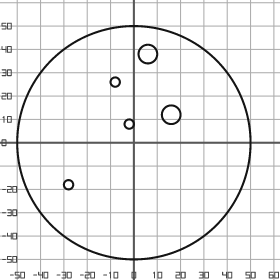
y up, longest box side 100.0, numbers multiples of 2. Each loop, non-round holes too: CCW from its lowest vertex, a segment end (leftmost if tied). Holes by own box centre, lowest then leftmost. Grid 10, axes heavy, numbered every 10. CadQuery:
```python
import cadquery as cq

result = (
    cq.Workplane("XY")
    .moveTo(0.0, 0.0)
    .circle(50.0)
    .moveTo(-28.0, -18.0)
    .circle(2.0)
    .moveTo(-2.0, 8.0)
    .circle(2.0)
    .moveTo(16.0, 12.0)
    .circle(4.0)
    .moveTo(-8.0, 26.0)
    .circle(2.0)
    .moveTo(6.0, 38.0)
    .circle(4.0)
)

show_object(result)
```